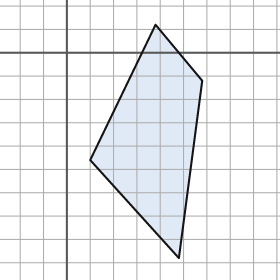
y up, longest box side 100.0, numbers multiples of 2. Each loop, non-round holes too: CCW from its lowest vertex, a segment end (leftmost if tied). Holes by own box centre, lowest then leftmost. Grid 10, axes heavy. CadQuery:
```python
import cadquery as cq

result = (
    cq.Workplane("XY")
    .moveTo(48.0, -88.0)
    .lineTo(58.0, -12.0)
    .lineTo(38.0, 12.0)
    .lineTo(10.0, -46.0)
    .close()
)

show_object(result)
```